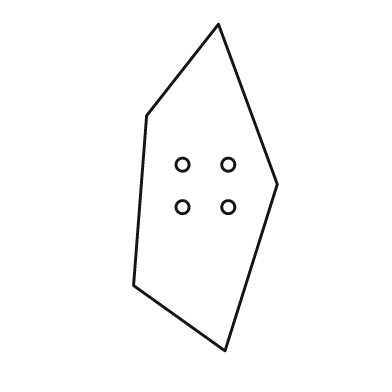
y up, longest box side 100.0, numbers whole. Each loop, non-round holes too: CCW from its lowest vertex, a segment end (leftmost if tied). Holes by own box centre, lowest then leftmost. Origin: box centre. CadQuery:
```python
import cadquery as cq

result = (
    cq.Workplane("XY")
    .moveTo(6.0, -50.0)
    .lineTo(22.0, 1.0)
    .lineTo(4.0, 50.0)
    .lineTo(-18.0, 22.0)
    .lineTo(-22.0, -30.0)
    .close()
    .moveTo(-7.0, -6.0)
    .circle(2.0)
    .moveTo(7.0, -6.0)
    .circle(2.0)
    .moveTo(-7.0, 7.0)
    .circle(2.0)
    .moveTo(7.0, 7.0)
    .circle(2.0)
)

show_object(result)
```